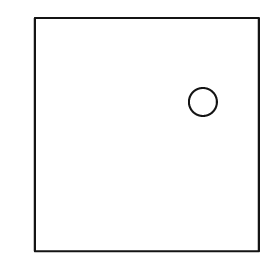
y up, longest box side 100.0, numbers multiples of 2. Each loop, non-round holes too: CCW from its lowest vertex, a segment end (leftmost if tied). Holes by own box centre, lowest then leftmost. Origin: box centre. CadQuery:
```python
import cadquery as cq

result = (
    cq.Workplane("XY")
    .moveTo(-48.0, -50.0)
    .lineTo(48.0, -50.0)
    .lineTo(48.0, 50.0)
    .lineTo(-48.0, 50.0)
    .close()
    .moveTo(24.0, 14.0)
    .circle(6.0)
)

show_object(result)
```